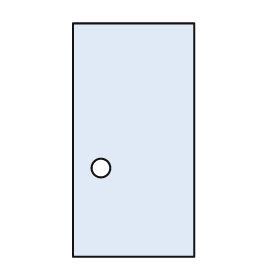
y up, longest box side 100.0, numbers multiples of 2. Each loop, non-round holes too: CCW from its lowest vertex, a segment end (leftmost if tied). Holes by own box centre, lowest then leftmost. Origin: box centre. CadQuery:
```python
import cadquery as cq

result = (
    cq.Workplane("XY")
    .moveTo(-26.0, -50.0)
    .lineTo(26.0, -50.0)
    .lineTo(26.0, 50.0)
    .lineTo(-26.0, 50.0)
    .close()
    .moveTo(-14.0, -12.0)
    .circle(4.0)
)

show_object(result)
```